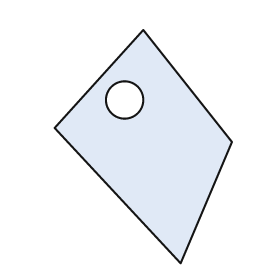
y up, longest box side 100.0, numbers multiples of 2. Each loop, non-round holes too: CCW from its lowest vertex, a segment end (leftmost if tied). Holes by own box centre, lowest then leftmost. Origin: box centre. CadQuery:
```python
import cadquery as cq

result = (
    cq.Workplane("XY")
    .moveTo(16.0, -50.0)
    .lineTo(38.0, 2.0)
    .lineTo(0.0, 50.0)
    .lineTo(-38.0, 8.0)
    .close()
    .moveTo(-8.0, 20.0)
    .circle(8.0)
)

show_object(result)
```